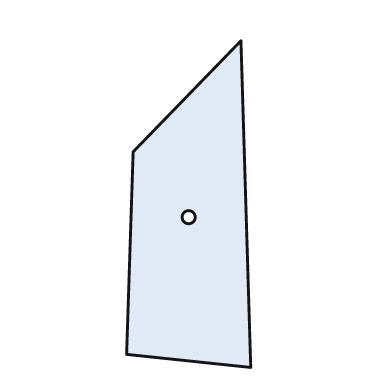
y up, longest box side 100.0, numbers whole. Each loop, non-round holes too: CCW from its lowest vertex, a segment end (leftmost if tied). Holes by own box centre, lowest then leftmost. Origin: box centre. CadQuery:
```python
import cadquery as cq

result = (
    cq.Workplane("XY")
    .moveTo(19.0, -50.0)
    .lineTo(16.0, 50.0)
    .lineTo(-17.0, 16.0)
    .lineTo(-19.0, -46.0)
    .close()
    .moveTo(0.0, -4.0)
    .circle(2.0)
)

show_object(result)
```